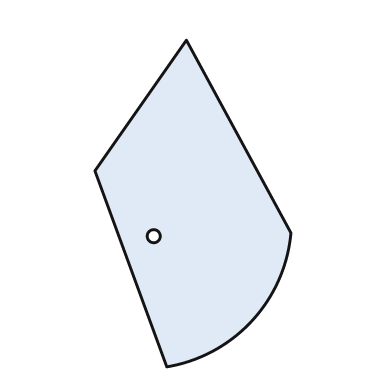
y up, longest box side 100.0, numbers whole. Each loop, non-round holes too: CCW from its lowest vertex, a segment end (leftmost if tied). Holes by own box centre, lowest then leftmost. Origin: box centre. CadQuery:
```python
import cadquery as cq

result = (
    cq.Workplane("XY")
    .moveTo(-8.0, -50.0)
    .threePointArc((18.0, -36.0), (30.0, -9.0))
    .lineTo(-2.0, 50.0)
    .lineTo(-30.0, 10.0)
    .close()
    .moveTo(-12.0, -10.0)
    .circle(2.0)
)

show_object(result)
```